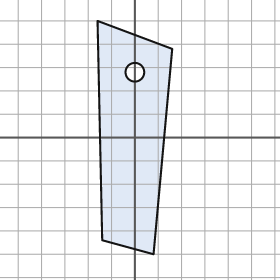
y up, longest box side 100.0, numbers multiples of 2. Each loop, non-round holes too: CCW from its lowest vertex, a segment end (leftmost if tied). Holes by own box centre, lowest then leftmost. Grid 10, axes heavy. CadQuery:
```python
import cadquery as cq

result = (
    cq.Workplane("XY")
    .moveTo(8.0, -50.0)
    .lineTo(16.0, 38.0)
    .lineTo(-16.0, 50.0)
    .lineTo(-14.0, -44.0)
    .close()
    .moveTo(0.0, 28.0)
    .circle(4.0)
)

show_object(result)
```